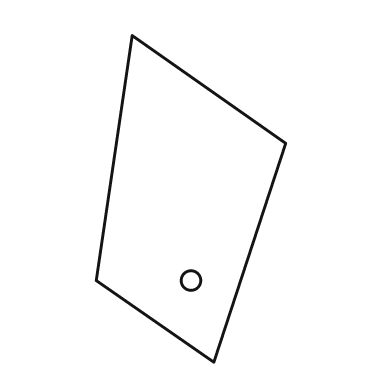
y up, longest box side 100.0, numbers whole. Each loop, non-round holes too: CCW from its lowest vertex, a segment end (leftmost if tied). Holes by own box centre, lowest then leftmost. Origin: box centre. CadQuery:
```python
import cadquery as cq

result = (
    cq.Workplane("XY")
    .moveTo(7.0, -50.0)
    .lineTo(29.0, 17.0)
    .lineTo(-18.0, 50.0)
    .lineTo(-29.0, -25.0)
    .close()
    .moveTo(0.0, -25.0)
    .circle(3.0)
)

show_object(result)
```